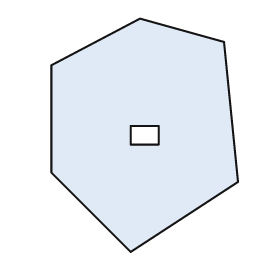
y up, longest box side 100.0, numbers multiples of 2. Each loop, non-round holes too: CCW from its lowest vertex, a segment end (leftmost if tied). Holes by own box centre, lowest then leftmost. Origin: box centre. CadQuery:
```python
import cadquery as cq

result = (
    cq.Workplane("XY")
    .moveTo(-6.0, -50.0)
    .lineTo(40.0, -20.0)
    .lineTo(34.0, 40.0)
    .lineTo(-2.0, 50.0)
    .lineTo(-40.0, 30.0)
    .lineTo(-40.0, -16.0)
    .close()
    .moveTo(-6.0, -4.0)
    .lineTo(6.0, -4.0)
    .lineTo(6.0, 4.0)
    .lineTo(-6.0, 4.0)
    .close()
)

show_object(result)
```